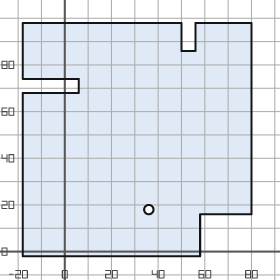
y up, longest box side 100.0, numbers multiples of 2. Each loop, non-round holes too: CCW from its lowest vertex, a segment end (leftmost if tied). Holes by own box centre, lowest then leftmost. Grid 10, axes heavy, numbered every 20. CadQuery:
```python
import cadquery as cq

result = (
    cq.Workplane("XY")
    .moveTo(-18.0, -2.0)
    .lineTo(58.0, -2.0)
    .lineTo(58.0, 16.0)
    .lineTo(80.0, 16.0)
    .lineTo(80.0, 98.0)
    .lineTo(56.0, 98.0)
    .lineTo(56.0, 86.0)
    .lineTo(50.0, 86.0)
    .lineTo(50.0, 98.0)
    .lineTo(-18.0, 98.0)
    .lineTo(-18.0, 74.0)
    .lineTo(6.0, 74.0)
    .lineTo(6.0, 68.0)
    .lineTo(-18.0, 68.0)
    .close()
    .moveTo(36.0, 18.0)
    .circle(2.0)
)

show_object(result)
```